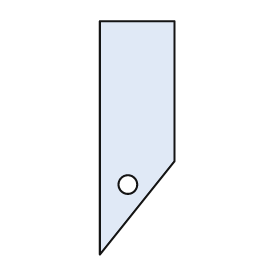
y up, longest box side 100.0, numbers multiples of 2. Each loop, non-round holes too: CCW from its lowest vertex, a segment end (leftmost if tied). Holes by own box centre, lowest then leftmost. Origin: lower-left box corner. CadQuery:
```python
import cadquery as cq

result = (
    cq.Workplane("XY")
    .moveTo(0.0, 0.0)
    .lineTo(32.0, 40.0)
    .lineTo(32.0, 100.0)
    .lineTo(0.0, 100.0)
    .close()
    .moveTo(12.0, 30.0)
    .circle(4.0)
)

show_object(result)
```